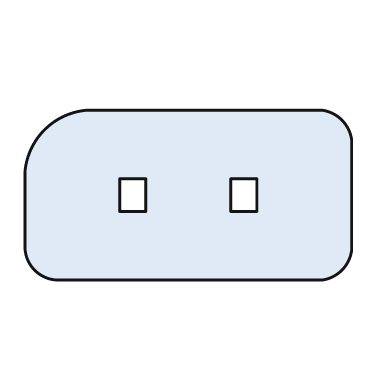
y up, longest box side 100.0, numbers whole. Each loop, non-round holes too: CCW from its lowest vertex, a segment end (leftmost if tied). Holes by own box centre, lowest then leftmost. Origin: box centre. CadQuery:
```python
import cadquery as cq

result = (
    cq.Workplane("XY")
    .moveTo(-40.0, -26.0)
    .lineTo(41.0, -26.0)
    .threePointArc((47.0, -23.0), (50.0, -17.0))
    .lineTo(50.0, 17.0)
    .threePointArc((47.0, 23.0), (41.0, 26.0))
    .lineTo(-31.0, 26.0)
    .threePointArc((-44.0, 20.0), (-50.0, 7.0))
    .lineTo(-50.0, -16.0)
    .threePointArc((-47.0, -23.0), (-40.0, -26.0))
    .close()
    .moveTo(-21.0, -5.0)
    .lineTo(-13.0, -5.0)
    .lineTo(-13.0, 5.0)
    .lineTo(-21.0, 5.0)
    .close()
    .moveTo(13.0, -5.0)
    .lineTo(21.0, -5.0)
    .lineTo(21.0, 5.0)
    .lineTo(13.0, 5.0)
    .close()
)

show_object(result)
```